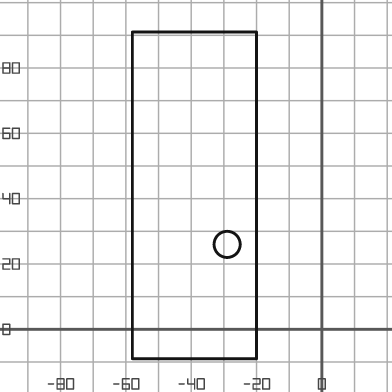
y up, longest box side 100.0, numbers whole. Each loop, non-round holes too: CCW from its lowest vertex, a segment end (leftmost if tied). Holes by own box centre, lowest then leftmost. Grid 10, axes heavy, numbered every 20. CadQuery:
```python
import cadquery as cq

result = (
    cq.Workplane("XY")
    .moveTo(-58.0, -9.0)
    .lineTo(-20.0, -9.0)
    .lineTo(-20.0, 91.0)
    .lineTo(-58.0, 91.0)
    .close()
    .moveTo(-29.0, 26.0)
    .circle(4.0)
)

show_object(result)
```